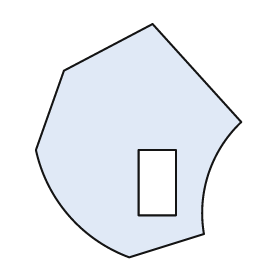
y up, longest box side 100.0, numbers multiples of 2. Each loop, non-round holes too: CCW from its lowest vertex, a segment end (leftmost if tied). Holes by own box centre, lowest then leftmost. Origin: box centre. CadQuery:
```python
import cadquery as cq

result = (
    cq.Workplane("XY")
    .moveTo(-4.0, -50.0)
    .lineTo(28.0, -40.0)
    .threePointArc((30.0, -14.0), (44.0, 8.0))
    .lineTo(6.0, 50.0)
    .lineTo(-32.0, 30.0)
    .lineTo(-44.0, -4.0)
    .threePointArc((-30.0, -32.0), (-4.0, -50.0))
    .close()
    .moveTo(0.0, -32.0)
    .lineTo(16.0, -32.0)
    .lineTo(16.0, -4.0)
    .lineTo(0.0, -4.0)
    .close()
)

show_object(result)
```